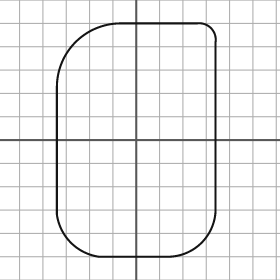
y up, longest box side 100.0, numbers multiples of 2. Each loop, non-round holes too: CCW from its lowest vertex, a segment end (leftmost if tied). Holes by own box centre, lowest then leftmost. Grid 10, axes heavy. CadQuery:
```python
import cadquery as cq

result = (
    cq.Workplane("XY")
    .moveTo(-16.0, -50.0)
    .lineTo(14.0, -50.0)
    .threePointArc((28.0, -44.0), (34.0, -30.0))
    .lineTo(34.0, 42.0)
    .threePointArc((32.0, 48.0), (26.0, 50.0))
    .lineTo(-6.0, 50.0)
    .threePointArc((-26.0, 42.0), (-34.0, 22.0))
    .lineTo(-34.0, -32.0)
    .threePointArc((-28.0, -44.0), (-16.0, -50.0))
    .close()
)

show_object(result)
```